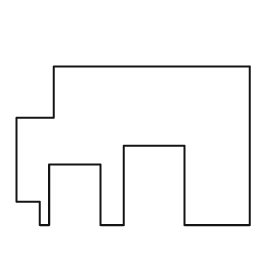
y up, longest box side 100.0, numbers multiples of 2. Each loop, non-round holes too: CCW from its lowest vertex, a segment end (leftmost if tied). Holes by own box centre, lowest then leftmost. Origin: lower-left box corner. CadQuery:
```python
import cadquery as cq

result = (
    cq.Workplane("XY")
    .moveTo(10.0, 0.0)
    .lineTo(14.0, 0.0)
    .lineTo(14.0, 26.0)
    .lineTo(36.0, 26.0)
    .lineTo(36.0, 0.0)
    .lineTo(46.0, 0.0)
    .lineTo(46.0, 34.0)
    .lineTo(72.0, 34.0)
    .lineTo(72.0, 0.0)
    .lineTo(100.0, 0.0)
    .lineTo(100.0, 68.0)
    .lineTo(16.0, 68.0)
    .lineTo(16.0, 46.0)
    .lineTo(0.0, 46.0)
    .lineTo(0.0, 10.0)
    .lineTo(10.0, 10.0)
    .close()
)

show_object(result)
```